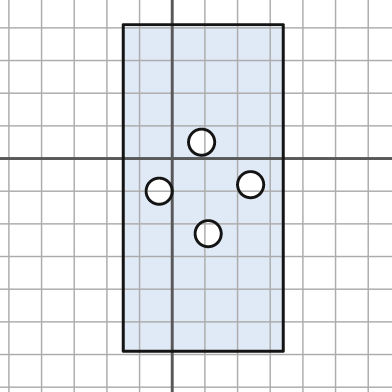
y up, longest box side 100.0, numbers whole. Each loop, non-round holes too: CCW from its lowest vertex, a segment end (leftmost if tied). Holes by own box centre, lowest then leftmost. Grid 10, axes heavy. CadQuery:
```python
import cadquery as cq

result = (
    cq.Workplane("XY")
    .moveTo(-15.0, -59.0)
    .lineTo(34.0, -59.0)
    .lineTo(34.0, 41.0)
    .lineTo(-15.0, 41.0)
    .close()
    .moveTo(11.0, -23.0)
    .circle(4.0)
    .moveTo(-4.0, -10.0)
    .circle(4.0)
    .moveTo(24.0, -8.0)
    .circle(4.0)
    .moveTo(9.0, 5.0)
    .circle(4.0)
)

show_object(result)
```